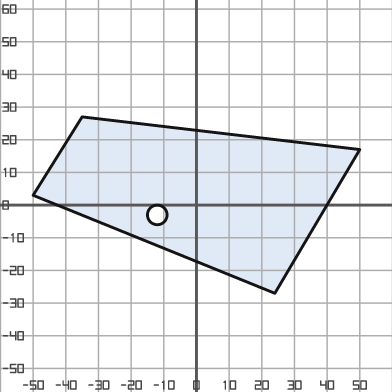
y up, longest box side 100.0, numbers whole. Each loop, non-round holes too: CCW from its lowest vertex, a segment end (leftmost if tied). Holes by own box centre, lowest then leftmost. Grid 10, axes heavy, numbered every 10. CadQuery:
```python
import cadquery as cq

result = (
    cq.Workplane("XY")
    .moveTo(24.0, -27.0)
    .lineTo(50.0, 17.0)
    .lineTo(-35.0, 27.0)
    .lineTo(-50.0, 3.0)
    .close()
    .moveTo(-12.0, -3.0)
    .circle(3.0)
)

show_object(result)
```